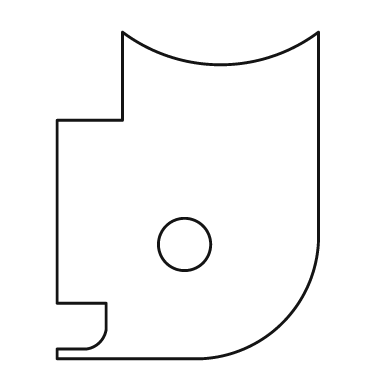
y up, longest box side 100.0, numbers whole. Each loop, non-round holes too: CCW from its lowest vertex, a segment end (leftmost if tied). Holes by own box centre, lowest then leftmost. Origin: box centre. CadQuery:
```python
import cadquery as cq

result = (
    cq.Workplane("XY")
    .moveTo(-40.0, -50.0)
    .lineTo(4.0, -50.0)
    .threePointArc((29.0, -39.0), (40.0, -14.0))
    .lineTo(40.0, 50.0)
    .threePointArc((10.0, 40.0), (-20.0, 50.0))
    .lineTo(-20.0, 23.0)
    .lineTo(-40.0, 23.0)
    .lineTo(-40.0, -33.0)
    .lineTo(-25.0, -33.0)
    .lineTo(-25.0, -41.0)
    .threePointArc((-27.0, -45.0), (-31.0, -47.0))
    .lineTo(-40.0, -47.0)
    .close()
    .moveTo(-1.0, -15.0)
    .circle(8.0)
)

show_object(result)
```